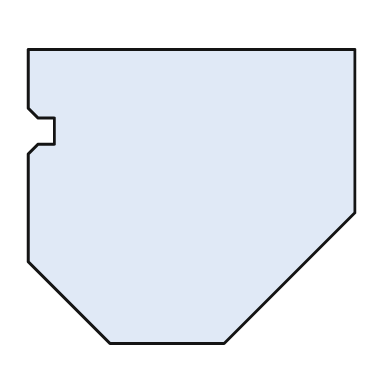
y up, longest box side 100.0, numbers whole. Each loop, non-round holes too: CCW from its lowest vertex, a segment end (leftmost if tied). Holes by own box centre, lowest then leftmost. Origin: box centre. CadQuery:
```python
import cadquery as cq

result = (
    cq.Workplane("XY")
    .moveTo(-25.0, -45.0)
    .lineTo(10.0, -45.0)
    .lineTo(50.0, -5.0)
    .lineTo(50.0, 45.0)
    .lineTo(-50.0, 45.0)
    .lineTo(-50.0, 27.0)
    .lineTo(-47.0, 24.0)
    .lineTo(-42.0, 24.0)
    .lineTo(-42.0, 16.0)
    .lineTo(-47.0, 16.0)
    .lineTo(-50.0, 13.0)
    .lineTo(-50.0, -20.0)
    .close()
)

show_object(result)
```